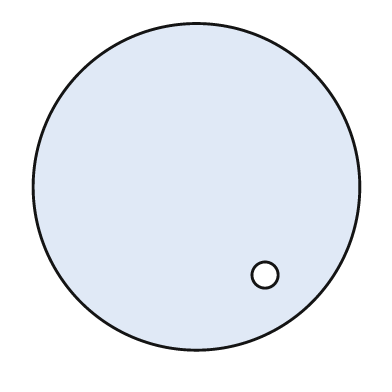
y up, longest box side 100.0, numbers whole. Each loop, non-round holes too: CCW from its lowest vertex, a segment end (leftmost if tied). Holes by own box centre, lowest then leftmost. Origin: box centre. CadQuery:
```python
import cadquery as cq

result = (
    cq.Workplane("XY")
    .moveTo(0.0, 0.0)
    .circle(50.0)
    .moveTo(21.0, -27.0)
    .circle(4.0)
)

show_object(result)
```